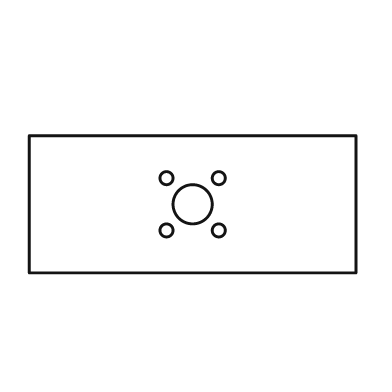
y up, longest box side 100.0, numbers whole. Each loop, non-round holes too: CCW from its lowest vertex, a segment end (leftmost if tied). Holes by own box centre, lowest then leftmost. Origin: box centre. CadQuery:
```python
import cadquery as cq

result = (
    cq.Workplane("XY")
    .moveTo(-50.0, -21.0)
    .lineTo(50.0, -21.0)
    .lineTo(50.0, 21.0)
    .lineTo(-50.0, 21.0)
    .close()
    .moveTo(-8.0, -8.0)
    .circle(2.0)
    .moveTo(8.0, -8.0)
    .circle(2.0)
    .moveTo(0.0, 0.0)
    .circle(6.0)
    .moveTo(-8.0, 8.0)
    .circle(2.0)
    .moveTo(8.0, 8.0)
    .circle(2.0)
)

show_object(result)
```